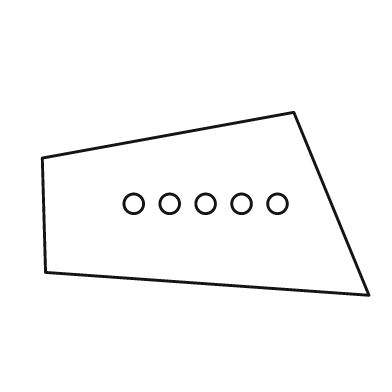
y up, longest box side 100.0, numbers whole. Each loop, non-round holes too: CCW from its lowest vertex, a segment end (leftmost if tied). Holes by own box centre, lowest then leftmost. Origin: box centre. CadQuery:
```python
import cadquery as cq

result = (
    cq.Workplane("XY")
    .moveTo(50.0, -28.0)
    .lineTo(27.0, 28.0)
    .lineTo(-50.0, 14.0)
    .lineTo(-49.0, -21.0)
    .close()
    .moveTo(-22.0, 0.0)
    .circle(3.0)
    .moveTo(-11.0, 0.0)
    .circle(3.0)
    .moveTo(0.0, 0.0)
    .circle(3.0)
    .moveTo(11.0, 0.0)
    .circle(3.0)
    .moveTo(22.0, 0.0)
    .circle(3.0)
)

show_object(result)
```